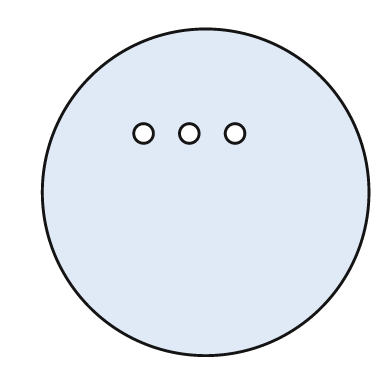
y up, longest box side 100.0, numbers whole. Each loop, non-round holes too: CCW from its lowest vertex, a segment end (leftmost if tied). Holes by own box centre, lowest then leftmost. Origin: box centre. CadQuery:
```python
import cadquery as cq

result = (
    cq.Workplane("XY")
    .moveTo(0.0, 0.0)
    .circle(50.0)
    .moveTo(-19.0, 18.0)
    .circle(3.0)
    .moveTo(-5.0, 18.0)
    .circle(3.0)
    .moveTo(9.0, 18.0)
    .circle(3.0)
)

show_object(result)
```